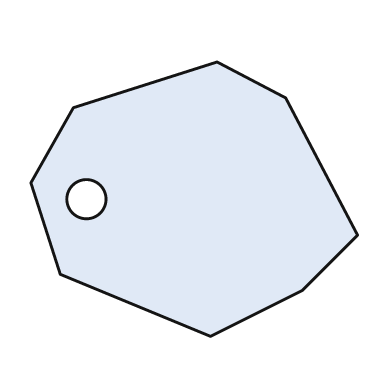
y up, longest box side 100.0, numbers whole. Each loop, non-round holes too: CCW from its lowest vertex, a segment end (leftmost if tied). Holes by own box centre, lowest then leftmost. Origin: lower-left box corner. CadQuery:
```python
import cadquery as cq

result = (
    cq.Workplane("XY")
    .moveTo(55.0, 0.0)
    .lineTo(83.0, 14.0)
    .lineTo(100.0, 31.0)
    .lineTo(78.0, 73.0)
    .lineTo(57.0, 84.0)
    .lineTo(13.0, 70.0)
    .lineTo(0.0, 47.0)
    .lineTo(9.0, 19.0)
    .close()
    .moveTo(17.0, 42.0)
    .circle(6.0)
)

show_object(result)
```